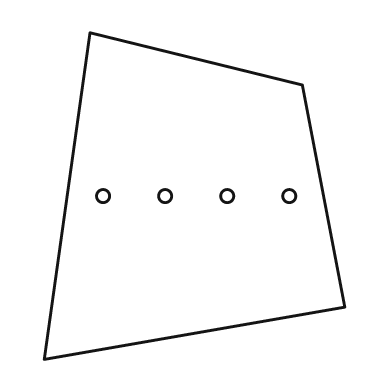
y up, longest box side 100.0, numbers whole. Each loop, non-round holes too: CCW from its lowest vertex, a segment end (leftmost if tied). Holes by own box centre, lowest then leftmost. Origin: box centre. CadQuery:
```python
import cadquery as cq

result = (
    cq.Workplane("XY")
    .moveTo(-46.0, -50.0)
    .lineTo(46.0, -34.0)
    .lineTo(33.0, 34.0)
    .lineTo(-32.0, 50.0)
    .close()
    .moveTo(-28.0, 0.0)
    .circle(2.0)
    .moveTo(-9.0, 0.0)
    .circle(2.0)
    .moveTo(10.0, 0.0)
    .circle(2.0)
    .moveTo(29.0, 0.0)
    .circle(2.0)
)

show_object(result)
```